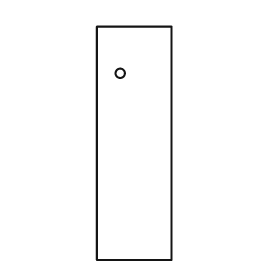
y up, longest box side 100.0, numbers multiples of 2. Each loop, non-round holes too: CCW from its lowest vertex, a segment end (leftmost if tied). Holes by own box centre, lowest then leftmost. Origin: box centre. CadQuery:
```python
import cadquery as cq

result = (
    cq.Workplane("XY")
    .moveTo(-16.0, -50.0)
    .lineTo(16.0, -50.0)
    .lineTo(16.0, 50.0)
    .lineTo(-16.0, 50.0)
    .close()
    .moveTo(-6.0, 30.0)
    .circle(2.0)
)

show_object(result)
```